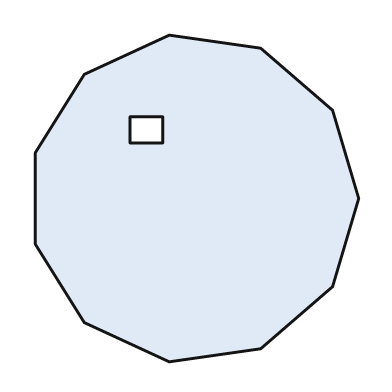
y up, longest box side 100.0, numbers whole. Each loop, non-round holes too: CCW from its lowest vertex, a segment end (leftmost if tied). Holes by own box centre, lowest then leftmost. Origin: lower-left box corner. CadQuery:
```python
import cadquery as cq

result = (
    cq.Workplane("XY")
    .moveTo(41.0, 0.0)
    .lineTo(69.0, 4.0)
    .lineTo(91.0, 23.0)
    .lineTo(99.0, 50.0)
    .lineTo(91.0, 77.0)
    .lineTo(69.0, 96.0)
    .lineTo(41.0, 100.0)
    .lineTo(15.0, 88.0)
    .lineTo(0.0, 64.0)
    .lineTo(0.0, 36.0)
    .lineTo(15.0, 12.0)
    .close()
    .moveTo(29.0, 67.0)
    .lineTo(39.0, 67.0)
    .lineTo(39.0, 75.0)
    .lineTo(29.0, 75.0)
    .close()
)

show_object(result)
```